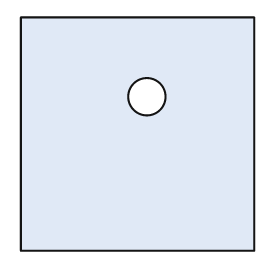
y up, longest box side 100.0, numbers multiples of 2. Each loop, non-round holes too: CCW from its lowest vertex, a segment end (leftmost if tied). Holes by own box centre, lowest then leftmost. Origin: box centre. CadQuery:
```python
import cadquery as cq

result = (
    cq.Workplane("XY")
    .moveTo(-50.0, -50.0)
    .lineTo(50.0, -50.0)
    .lineTo(50.0, 50.0)
    .lineTo(-50.0, 50.0)
    .close()
    .moveTo(4.0, 16.0)
    .circle(8.0)
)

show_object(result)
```